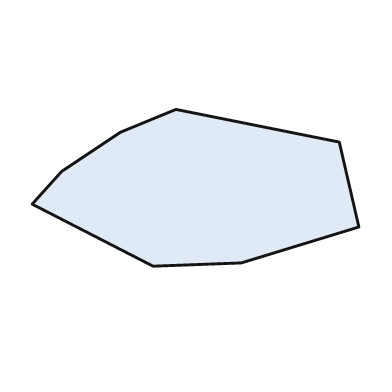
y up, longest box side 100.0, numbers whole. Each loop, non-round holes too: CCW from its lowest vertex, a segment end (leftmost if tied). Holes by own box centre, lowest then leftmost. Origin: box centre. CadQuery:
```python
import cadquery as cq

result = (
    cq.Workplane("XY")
    .moveTo(-13.0, -24.0)
    .lineTo(14.0, -23.0)
    .lineTo(50.0, -12.0)
    .lineTo(44.0, 14.0)
    .lineTo(-6.0, 24.0)
    .lineTo(-23.0, 17.0)
    .lineTo(-41.0, 5.0)
    .lineTo(-50.0, -5.0)
    .close()
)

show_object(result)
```